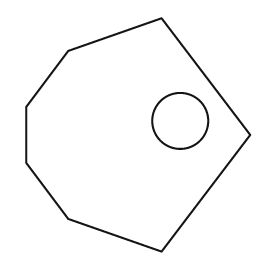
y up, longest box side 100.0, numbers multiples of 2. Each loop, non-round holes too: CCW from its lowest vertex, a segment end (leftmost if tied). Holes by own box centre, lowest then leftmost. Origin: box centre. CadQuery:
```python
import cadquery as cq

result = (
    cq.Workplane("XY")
    .moveTo(10.0, -50.0)
    .lineTo(48.0, 0.0)
    .lineTo(10.0, 50.0)
    .lineTo(-30.0, 36.0)
    .lineTo(-48.0, 12.0)
    .lineTo(-48.0, -12.0)
    .lineTo(-30.0, -36.0)
    .close()
    .moveTo(18.0, 6.0)
    .circle(12.0)
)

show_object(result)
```